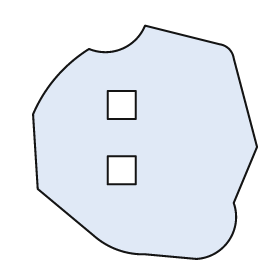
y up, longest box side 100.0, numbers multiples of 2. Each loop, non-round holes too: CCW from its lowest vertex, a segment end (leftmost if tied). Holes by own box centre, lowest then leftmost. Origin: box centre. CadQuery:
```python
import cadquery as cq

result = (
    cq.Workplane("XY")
    .moveTo(22.0, -50.0)
    .threePointArc((36.0, -42.0), (38.0, -26.0))
    .lineTo(48.0, -2.0)
    .lineTo(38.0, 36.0)
    .threePointArc((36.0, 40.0), (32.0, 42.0))
    .lineTo(0.0, 50.0)
    .threePointArc((-10.0, 40.0), (-24.0, 40.0))
    .threePointArc((-38.0, 28.0), (-48.0, 12.0))
    .lineTo(-46.0, -20.0)
    .lineTo(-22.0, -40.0)
    .threePointArc((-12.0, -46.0), (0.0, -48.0))
    .close()
    .moveTo(-16.0, -18.0)
    .lineTo(-4.0, -18.0)
    .lineTo(-4.0, -6.0)
    .lineTo(-16.0, -6.0)
    .close()
    .moveTo(-16.0, 10.0)
    .lineTo(-4.0, 10.0)
    .lineTo(-4.0, 22.0)
    .lineTo(-16.0, 22.0)
    .close()
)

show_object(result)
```